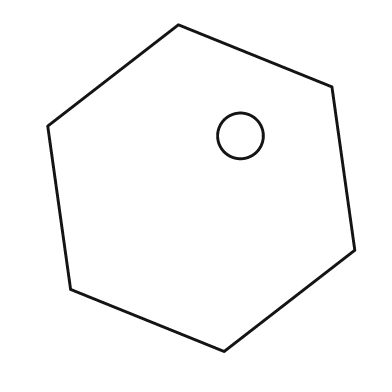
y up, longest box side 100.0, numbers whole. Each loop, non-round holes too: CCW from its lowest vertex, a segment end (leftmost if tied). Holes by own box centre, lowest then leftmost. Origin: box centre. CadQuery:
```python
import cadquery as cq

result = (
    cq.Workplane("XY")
    .moveTo(7.0, -50.0)
    .lineTo(47.0, -19.0)
    .lineTo(40.0, 31.0)
    .lineTo(-7.0, 50.0)
    .lineTo(-47.0, 19.0)
    .lineTo(-40.0, -31.0)
    .close()
    .moveTo(12.0, 16.0)
    .circle(7.0)
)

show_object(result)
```